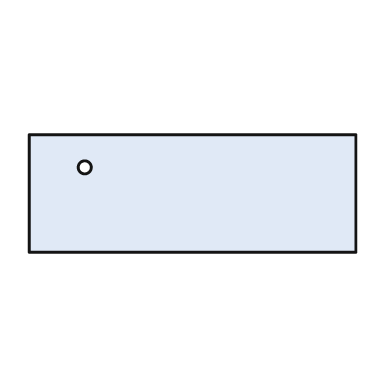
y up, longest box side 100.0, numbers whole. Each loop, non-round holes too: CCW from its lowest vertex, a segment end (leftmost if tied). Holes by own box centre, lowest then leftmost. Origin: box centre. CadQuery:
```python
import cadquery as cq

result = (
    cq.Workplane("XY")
    .moveTo(-50.0, -18.0)
    .lineTo(50.0, -18.0)
    .lineTo(50.0, 18.0)
    .lineTo(-50.0, 18.0)
    .close()
    .moveTo(-33.0, 8.0)
    .circle(2.0)
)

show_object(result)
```